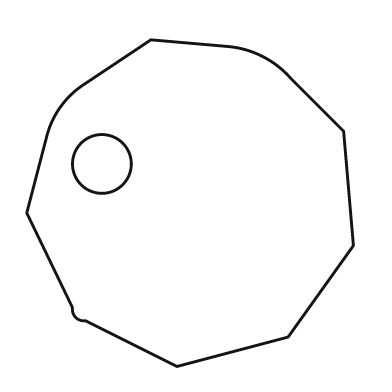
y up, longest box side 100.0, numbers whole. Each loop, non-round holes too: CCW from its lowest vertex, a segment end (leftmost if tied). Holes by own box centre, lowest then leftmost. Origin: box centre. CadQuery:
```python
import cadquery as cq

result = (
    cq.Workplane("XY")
    .moveTo(-4.0, -50.0)
    .lineTo(30.0, -41.0)
    .lineTo(50.0, -13.0)
    .lineTo(47.0, 22.0)
    .lineTo(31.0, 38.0)
    .threePointArc((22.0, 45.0), (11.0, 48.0))
    .lineTo(-12.0, 50.0)
    .lineTo(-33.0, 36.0)
    .threePointArc((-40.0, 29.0), (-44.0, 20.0))
    .lineTo(-50.0, -3.0)
    .lineTo(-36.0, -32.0)
    .threePointArc((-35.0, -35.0), (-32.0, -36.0))
    .close()
    .moveTo(-27.0, 12.0)
    .circle(9.0)
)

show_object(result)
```